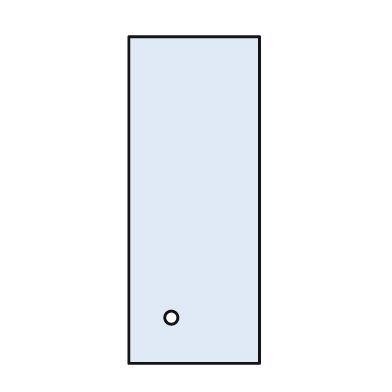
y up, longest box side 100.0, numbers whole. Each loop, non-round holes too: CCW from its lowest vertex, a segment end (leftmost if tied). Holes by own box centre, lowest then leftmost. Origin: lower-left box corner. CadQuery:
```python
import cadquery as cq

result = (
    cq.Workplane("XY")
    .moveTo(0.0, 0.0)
    .lineTo(40.0, 0.0)
    .lineTo(40.0, 100.0)
    .lineTo(0.0, 100.0)
    .close()
    .moveTo(13.0, 14.0)
    .circle(2.0)
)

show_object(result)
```